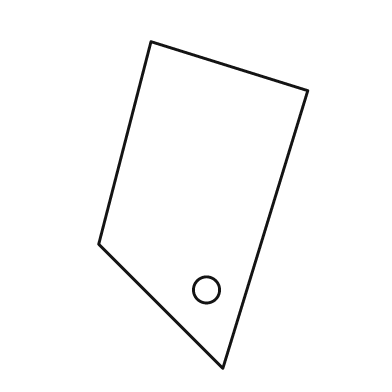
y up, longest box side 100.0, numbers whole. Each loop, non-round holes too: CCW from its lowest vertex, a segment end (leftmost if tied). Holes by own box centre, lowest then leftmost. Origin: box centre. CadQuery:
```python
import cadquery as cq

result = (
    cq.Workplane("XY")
    .moveTo(6.0, -50.0)
    .lineTo(32.0, 35.0)
    .lineTo(-16.0, 50.0)
    .lineTo(-32.0, -12.0)
    .close()
    .moveTo(1.0, -26.0)
    .circle(4.0)
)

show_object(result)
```